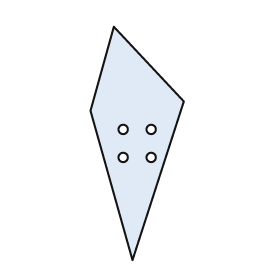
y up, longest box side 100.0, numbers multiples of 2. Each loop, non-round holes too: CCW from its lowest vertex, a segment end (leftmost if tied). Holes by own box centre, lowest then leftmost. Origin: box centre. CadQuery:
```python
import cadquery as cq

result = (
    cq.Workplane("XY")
    .moveTo(-2.0, -50.0)
    .lineTo(20.0, 18.0)
    .lineTo(-10.0, 50.0)
    .lineTo(-20.0, 14.0)
    .close()
    .moveTo(-6.0, -6.0)
    .circle(2.0)
    .moveTo(6.0, -6.0)
    .circle(2.0)
    .moveTo(-6.0, 6.0)
    .circle(2.0)
    .moveTo(6.0, 6.0)
    .circle(2.0)
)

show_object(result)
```